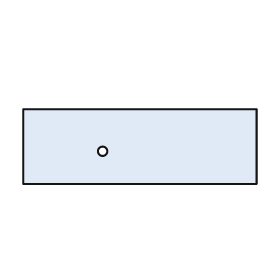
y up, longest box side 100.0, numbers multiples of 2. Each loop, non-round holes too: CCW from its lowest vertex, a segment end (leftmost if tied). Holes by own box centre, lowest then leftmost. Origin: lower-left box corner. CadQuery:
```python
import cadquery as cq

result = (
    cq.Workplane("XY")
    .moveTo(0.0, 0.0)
    .lineTo(100.0, 0.0)
    .lineTo(100.0, 32.0)
    .lineTo(0.0, 32.0)
    .close()
    .moveTo(34.0, 14.0)
    .circle(2.0)
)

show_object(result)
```